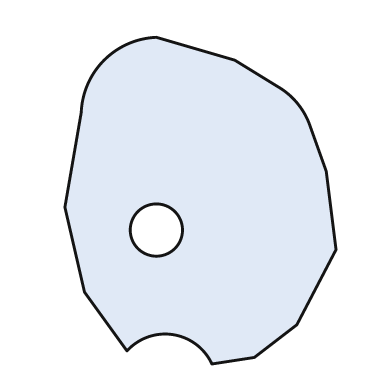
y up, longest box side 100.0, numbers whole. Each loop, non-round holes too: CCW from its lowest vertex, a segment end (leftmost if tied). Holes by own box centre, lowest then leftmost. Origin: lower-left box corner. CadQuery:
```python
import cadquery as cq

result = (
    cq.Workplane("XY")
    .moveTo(45.0, 0.0)
    .lineTo(58.0, 2.0)
    .lineTo(71.0, 12.0)
    .lineTo(83.0, 35.0)
    .lineTo(80.0, 59.0)
    .lineTo(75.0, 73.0)
    .threePointArc((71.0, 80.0), (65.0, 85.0))
    .lineTo(52.0, 93.0)
    .lineTo(28.0, 100.0)
    .threePointArc((12.0, 93.0), (5.0, 77.0))
    .lineTo(0.0, 48.0)
    .lineTo(6.0, 22.0)
    .lineTo(19.0, 4.0)
    .threePointArc((33.0, 9.0), (45.0, 0.0))
    .close()
    .moveTo(28.0, 41.0)
    .circle(8.0)
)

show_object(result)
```